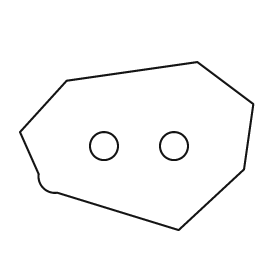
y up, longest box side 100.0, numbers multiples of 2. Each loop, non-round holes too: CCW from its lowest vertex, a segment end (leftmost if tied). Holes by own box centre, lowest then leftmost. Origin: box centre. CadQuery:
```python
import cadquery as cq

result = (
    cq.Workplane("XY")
    .moveTo(18.0, -36.0)
    .lineTo(46.0, -10.0)
    .lineTo(50.0, 18.0)
    .lineTo(26.0, 36.0)
    .lineTo(-30.0, 28.0)
    .lineTo(-50.0, 6.0)
    .lineTo(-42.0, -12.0)
    .threePointArc((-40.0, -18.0), (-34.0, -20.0))
    .close()
    .moveTo(-14.0, 0.0)
    .circle(6.0)
    .moveTo(16.0, 0.0)
    .circle(6.0)
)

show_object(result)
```